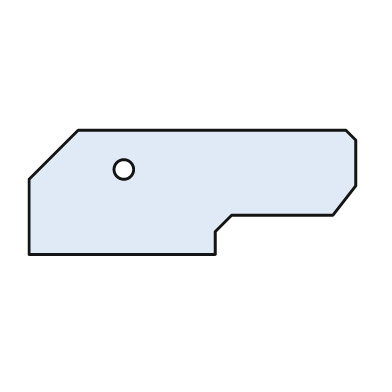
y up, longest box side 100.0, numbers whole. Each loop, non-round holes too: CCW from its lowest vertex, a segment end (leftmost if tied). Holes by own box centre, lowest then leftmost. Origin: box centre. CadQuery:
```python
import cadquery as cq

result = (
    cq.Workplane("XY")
    .moveTo(-50.0, -19.0)
    .lineTo(7.0, -19.0)
    .lineTo(7.0, -12.0)
    .lineTo(12.0, -7.0)
    .lineTo(43.0, -7.0)
    .lineTo(50.0, 2.0)
    .lineTo(50.0, 16.0)
    .lineTo(47.0, 19.0)
    .lineTo(-35.0, 19.0)
    .lineTo(-50.0, 4.0)
    .close()
    .moveTo(-21.0, 7.0)
    .circle(3.0)
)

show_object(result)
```